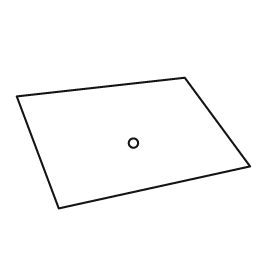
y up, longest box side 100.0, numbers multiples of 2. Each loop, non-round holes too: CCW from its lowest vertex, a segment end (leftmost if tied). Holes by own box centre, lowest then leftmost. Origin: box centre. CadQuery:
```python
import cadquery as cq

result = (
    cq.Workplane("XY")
    .moveTo(-32.0, -28.0)
    .lineTo(50.0, -10.0)
    .lineTo(22.0, 28.0)
    .lineTo(-50.0, 20.0)
    .close()
    .moveTo(0.0, 0.0)
    .circle(2.0)
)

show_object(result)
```